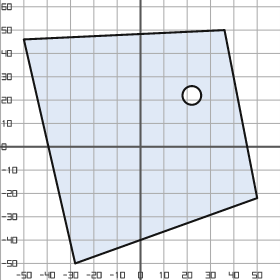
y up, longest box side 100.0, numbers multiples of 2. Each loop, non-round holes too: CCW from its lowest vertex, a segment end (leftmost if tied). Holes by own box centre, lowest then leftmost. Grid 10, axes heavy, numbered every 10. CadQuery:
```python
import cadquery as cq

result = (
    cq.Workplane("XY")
    .moveTo(-28.0, -50.0)
    .lineTo(50.0, -22.0)
    .lineTo(36.0, 50.0)
    .lineTo(-50.0, 46.0)
    .close()
    .moveTo(22.0, 22.0)
    .circle(4.0)
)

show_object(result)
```